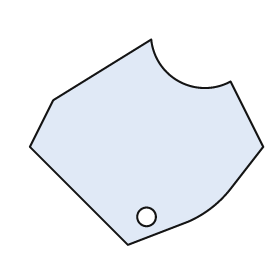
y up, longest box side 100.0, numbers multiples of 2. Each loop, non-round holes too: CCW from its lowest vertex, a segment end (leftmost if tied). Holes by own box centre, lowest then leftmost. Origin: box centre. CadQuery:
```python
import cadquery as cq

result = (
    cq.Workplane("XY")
    .moveTo(-8.0, -44.0)
    .lineTo(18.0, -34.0)
    .threePointArc((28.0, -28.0), (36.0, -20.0))
    .lineTo(50.0, -2.0)
    .lineTo(36.0, 26.0)
    .threePointArc((14.0, 26.0), (2.0, 44.0))
    .lineTo(-40.0, 18.0)
    .lineTo(-50.0, -2.0)
    .close()
    .moveTo(0.0, -32.0)
    .circle(4.0)
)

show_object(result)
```